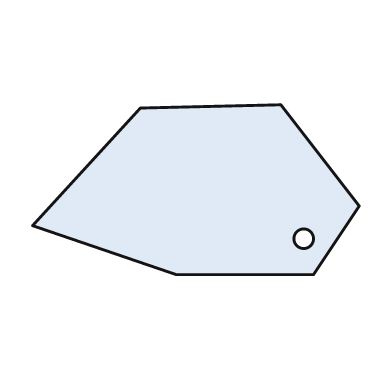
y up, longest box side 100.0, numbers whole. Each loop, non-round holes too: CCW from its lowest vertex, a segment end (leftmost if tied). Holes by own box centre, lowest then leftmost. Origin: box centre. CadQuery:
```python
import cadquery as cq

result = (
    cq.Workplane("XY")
    .moveTo(-6.0, -26.0)
    .lineTo(36.0, -26.0)
    .lineTo(50.0, -5.0)
    .lineTo(26.0, 26.0)
    .lineTo(-17.0, 25.0)
    .lineTo(-50.0, -11.0)
    .close()
    .moveTo(33.0, -15.0)
    .circle(3.0)
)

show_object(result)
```